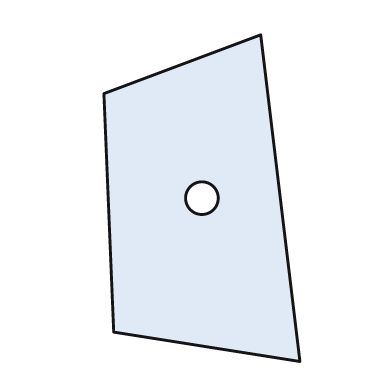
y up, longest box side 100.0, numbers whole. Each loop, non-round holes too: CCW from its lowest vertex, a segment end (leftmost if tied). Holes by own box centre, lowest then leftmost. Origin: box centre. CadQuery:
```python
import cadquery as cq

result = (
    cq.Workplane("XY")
    .moveTo(30.0, -50.0)
    .lineTo(18.0, 50.0)
    .lineTo(-30.0, 32.0)
    .lineTo(-27.0, -41.0)
    .close()
    .moveTo(0.0, 0.0)
    .circle(5.0)
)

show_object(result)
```